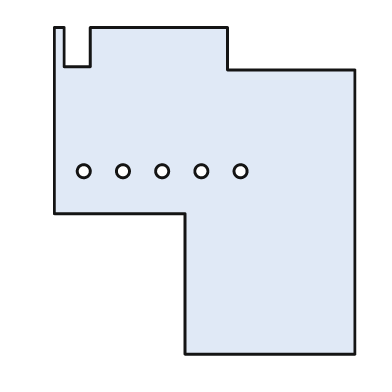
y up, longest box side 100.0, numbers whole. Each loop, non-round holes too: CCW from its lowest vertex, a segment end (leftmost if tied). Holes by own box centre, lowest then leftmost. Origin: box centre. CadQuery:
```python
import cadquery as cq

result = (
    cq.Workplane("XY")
    .moveTo(-6.0, -50.0)
    .lineTo(46.0, -50.0)
    .lineTo(46.0, 37.0)
    .lineTo(7.0, 37.0)
    .lineTo(7.0, 50.0)
    .lineTo(-35.0, 50.0)
    .lineTo(-35.0, 38.0)
    .lineTo(-43.0, 38.0)
    .lineTo(-43.0, 50.0)
    .lineTo(-46.0, 50.0)
    .lineTo(-46.0, -7.0)
    .lineTo(-6.0, -7.0)
    .close()
    .moveTo(-37.0, 6.0)
    .circle(2.0)
    .moveTo(-25.0, 6.0)
    .circle(2.0)
    .moveTo(-13.0, 6.0)
    .circle(2.0)
    .moveTo(-1.0, 6.0)
    .circle(2.0)
    .moveTo(11.0, 6.0)
    .circle(2.0)
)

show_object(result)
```